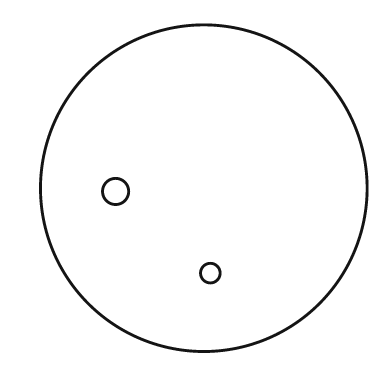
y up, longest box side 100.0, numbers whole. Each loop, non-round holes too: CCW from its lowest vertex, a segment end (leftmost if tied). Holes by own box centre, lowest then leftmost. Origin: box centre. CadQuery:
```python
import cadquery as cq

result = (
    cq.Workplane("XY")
    .moveTo(0.0, 0.0)
    .circle(50.0)
    .moveTo(2.0, -26.0)
    .circle(3.0)
    .moveTo(-27.0, -1.0)
    .circle(4.0)
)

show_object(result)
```